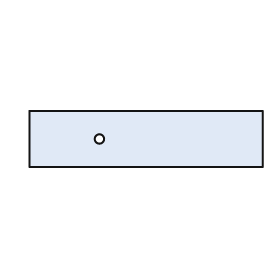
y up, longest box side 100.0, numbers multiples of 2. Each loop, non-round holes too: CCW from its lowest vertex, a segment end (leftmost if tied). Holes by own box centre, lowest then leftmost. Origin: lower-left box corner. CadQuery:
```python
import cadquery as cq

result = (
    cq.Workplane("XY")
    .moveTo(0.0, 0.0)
    .lineTo(100.0, 0.0)
    .lineTo(100.0, 24.0)
    .lineTo(0.0, 24.0)
    .close()
    .moveTo(30.0, 12.0)
    .circle(2.0)
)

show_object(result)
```